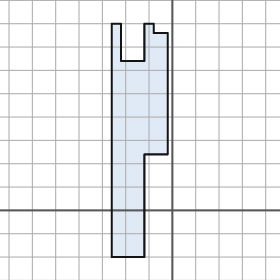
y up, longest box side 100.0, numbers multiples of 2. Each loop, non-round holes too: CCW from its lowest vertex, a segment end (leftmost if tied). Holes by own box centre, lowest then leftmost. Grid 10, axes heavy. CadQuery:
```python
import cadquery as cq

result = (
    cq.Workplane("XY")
    .moveTo(-26.0, -20.0)
    .lineTo(-12.0, -20.0)
    .lineTo(-12.0, 24.0)
    .lineTo(-2.0, 24.0)
    .lineTo(-2.0, 76.0)
    .lineTo(-8.0, 76.0)
    .lineTo(-8.0, 80.0)
    .lineTo(-12.0, 80.0)
    .lineTo(-12.0, 64.0)
    .lineTo(-22.0, 64.0)
    .lineTo(-22.0, 80.0)
    .lineTo(-26.0, 80.0)
    .close()
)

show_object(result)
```